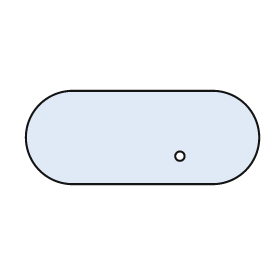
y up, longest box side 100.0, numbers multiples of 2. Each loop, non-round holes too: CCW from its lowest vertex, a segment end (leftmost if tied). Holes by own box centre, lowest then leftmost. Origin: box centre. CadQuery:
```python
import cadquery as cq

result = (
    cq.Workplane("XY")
    .moveTo(-30.0, -20.0)
    .lineTo(30.0, -20.0)
    .threePointArc((50.0, 0.0), (30.0, 20.0))
    .lineTo(-30.0, 20.0)
    .threePointArc((-50.0, 0.0), (-30.0, -20.0))
    .close()
    .moveTo(16.0, -8.0)
    .circle(2.0)
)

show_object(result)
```